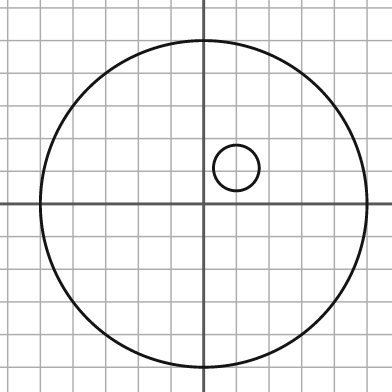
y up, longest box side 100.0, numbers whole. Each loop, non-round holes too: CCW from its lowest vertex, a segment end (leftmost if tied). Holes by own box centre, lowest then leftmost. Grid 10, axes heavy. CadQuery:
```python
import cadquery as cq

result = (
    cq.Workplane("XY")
    .moveTo(0.0, 0.0)
    .circle(50.0)
    .moveTo(10.0, 11.0)
    .circle(7.0)
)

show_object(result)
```